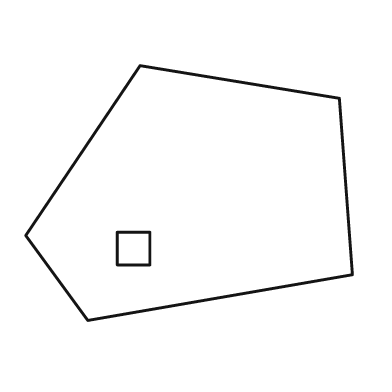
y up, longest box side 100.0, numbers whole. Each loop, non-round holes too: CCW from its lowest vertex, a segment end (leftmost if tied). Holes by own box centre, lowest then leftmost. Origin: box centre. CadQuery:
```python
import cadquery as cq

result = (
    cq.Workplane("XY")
    .moveTo(-31.0, -39.0)
    .lineTo(50.0, -25.0)
    .lineTo(46.0, 29.0)
    .lineTo(-15.0, 39.0)
    .lineTo(-50.0, -13.0)
    .close()
    .moveTo(-22.0, -22.0)
    .lineTo(-12.0, -22.0)
    .lineTo(-12.0, -12.0)
    .lineTo(-22.0, -12.0)
    .close()
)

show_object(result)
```